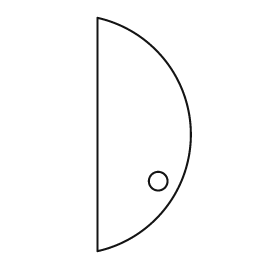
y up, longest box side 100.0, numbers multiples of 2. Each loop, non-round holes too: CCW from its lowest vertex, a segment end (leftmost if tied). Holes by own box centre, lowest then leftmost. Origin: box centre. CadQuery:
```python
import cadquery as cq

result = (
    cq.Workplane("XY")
    .moveTo(-20.0, -50.0)
    .threePointArc((20.0, 0.0), (-20.0, 50.0))
    .close()
    .moveTo(6.0, -20.0)
    .circle(4.0)
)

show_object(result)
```